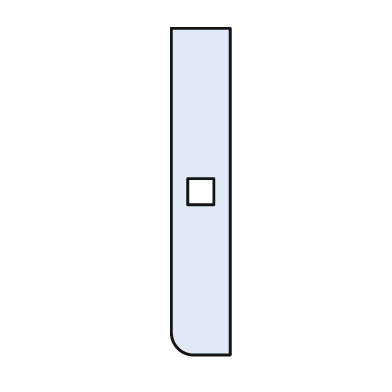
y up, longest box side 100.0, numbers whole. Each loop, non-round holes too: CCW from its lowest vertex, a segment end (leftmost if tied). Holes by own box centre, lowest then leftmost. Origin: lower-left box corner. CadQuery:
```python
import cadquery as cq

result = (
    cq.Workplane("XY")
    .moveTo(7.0, 0.0)
    .lineTo(18.0, 0.0)
    .lineTo(18.0, 100.0)
    .lineTo(0.0, 100.0)
    .lineTo(0.0, 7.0)
    .threePointArc((2.0, 2.0), (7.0, 0.0))
    .close()
    .moveTo(5.0, 46.0)
    .lineTo(13.0, 46.0)
    .lineTo(13.0, 54.0)
    .lineTo(5.0, 54.0)
    .close()
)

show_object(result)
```